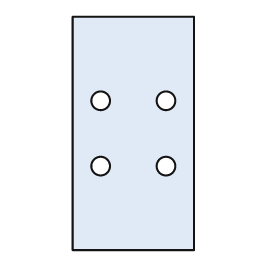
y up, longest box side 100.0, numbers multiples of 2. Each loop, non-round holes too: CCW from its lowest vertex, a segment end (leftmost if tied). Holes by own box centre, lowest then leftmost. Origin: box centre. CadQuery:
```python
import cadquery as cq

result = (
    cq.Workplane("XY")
    .moveTo(-26.0, -50.0)
    .lineTo(26.0, -50.0)
    .lineTo(26.0, 50.0)
    .lineTo(-26.0, 50.0)
    .close()
    .moveTo(-14.0, -14.0)
    .circle(4.0)
    .moveTo(14.0, -14.0)
    .circle(4.0)
    .moveTo(-14.0, 14.0)
    .circle(4.0)
    .moveTo(14.0, 14.0)
    .circle(4.0)
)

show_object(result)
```